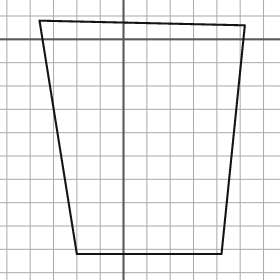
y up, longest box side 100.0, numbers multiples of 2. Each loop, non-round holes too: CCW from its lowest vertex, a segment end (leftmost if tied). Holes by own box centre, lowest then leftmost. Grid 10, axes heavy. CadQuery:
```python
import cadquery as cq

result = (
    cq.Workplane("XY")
    .moveTo(-20.0, -92.0)
    .lineTo(42.0, -92.0)
    .lineTo(52.0, 6.0)
    .lineTo(-36.0, 8.0)
    .close()
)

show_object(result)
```